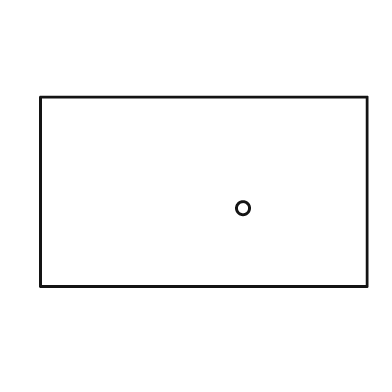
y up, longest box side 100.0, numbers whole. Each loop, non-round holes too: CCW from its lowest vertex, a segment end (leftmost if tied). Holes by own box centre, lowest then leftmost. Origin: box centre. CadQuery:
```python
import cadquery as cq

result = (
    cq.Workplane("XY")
    .moveTo(-50.0, -29.0)
    .lineTo(50.0, -29.0)
    .lineTo(50.0, 29.0)
    .lineTo(-50.0, 29.0)
    .close()
    .moveTo(12.0, -5.0)
    .circle(2.0)
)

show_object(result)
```